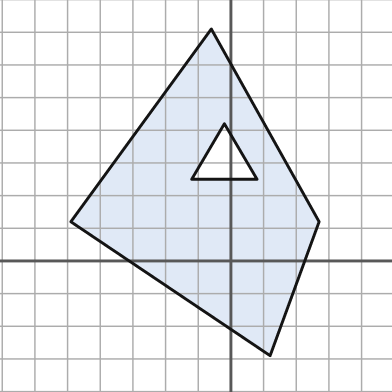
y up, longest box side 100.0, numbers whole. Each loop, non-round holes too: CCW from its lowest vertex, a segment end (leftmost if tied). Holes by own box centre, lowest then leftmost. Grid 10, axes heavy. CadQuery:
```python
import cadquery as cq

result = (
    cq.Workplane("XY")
    .moveTo(12.0, -29.0)
    .lineTo(27.0, 12.0)
    .lineTo(-6.0, 71.0)
    .lineTo(-49.0, 12.0)
    .close()
    .moveTo(-12.0, 25.0)
    .lineTo(8.0, 25.0)
    .lineTo(-2.0, 42.0)
    .close()
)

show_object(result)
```